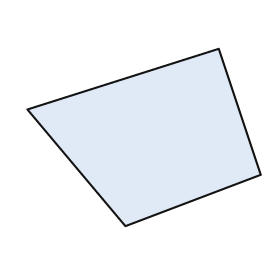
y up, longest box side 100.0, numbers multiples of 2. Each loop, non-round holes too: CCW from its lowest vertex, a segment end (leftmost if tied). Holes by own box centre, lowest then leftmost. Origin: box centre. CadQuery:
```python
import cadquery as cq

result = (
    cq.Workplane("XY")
    .moveTo(-8.0, -38.0)
    .lineTo(50.0, -16.0)
    .lineTo(32.0, 38.0)
    .lineTo(-50.0, 12.0)
    .close()
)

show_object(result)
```